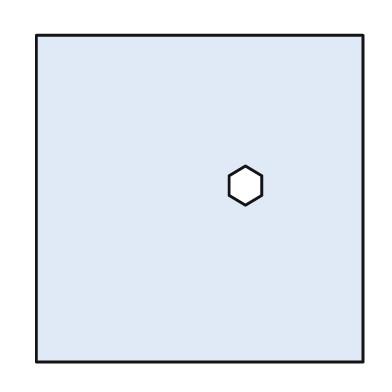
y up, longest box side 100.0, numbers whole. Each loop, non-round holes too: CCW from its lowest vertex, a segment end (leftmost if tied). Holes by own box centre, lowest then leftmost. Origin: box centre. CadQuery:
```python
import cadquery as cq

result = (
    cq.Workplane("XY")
    .moveTo(-50.0, -50.0)
    .lineTo(50.0, -50.0)
    .lineTo(50.0, 50.0)
    .lineTo(-50.0, 50.0)
    .close()
    .moveTo(14.0, -2.0)
    .lineTo(19.0, 1.0)
    .lineTo(19.0, 7.0)
    .lineTo(14.0, 10.0)
    .lineTo(9.0, 7.0)
    .lineTo(9.0, 1.0)
    .close()
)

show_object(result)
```